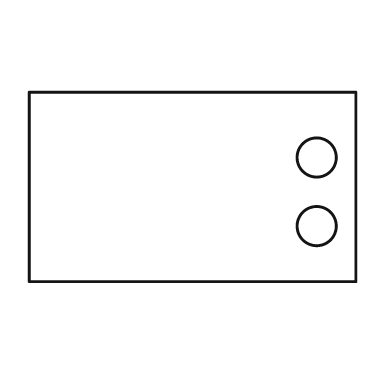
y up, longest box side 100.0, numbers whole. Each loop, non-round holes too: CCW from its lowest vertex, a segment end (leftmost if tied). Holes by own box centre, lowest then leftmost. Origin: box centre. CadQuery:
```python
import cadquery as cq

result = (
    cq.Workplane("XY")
    .moveTo(-50.0, -29.0)
    .lineTo(50.0, -29.0)
    .lineTo(50.0, 29.0)
    .lineTo(-50.0, 29.0)
    .close()
    .moveTo(38.0, -12.0)
    .circle(6.0)
    .moveTo(38.0, 9.0)
    .circle(6.0)
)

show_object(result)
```